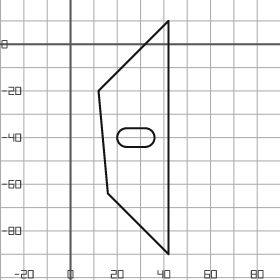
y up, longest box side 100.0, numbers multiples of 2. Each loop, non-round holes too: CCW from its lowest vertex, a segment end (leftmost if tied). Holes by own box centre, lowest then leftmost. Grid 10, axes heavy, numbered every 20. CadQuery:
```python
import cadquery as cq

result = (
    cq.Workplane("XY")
    .moveTo(42.0, -90.0)
    .lineTo(42.0, 10.0)
    .lineTo(12.0, -20.0)
    .lineTo(16.0, -64.0)
    .close()
    .moveTo(24.0, -44.0)
    .lineTo(32.0, -44.0)
    .threePointArc((36.0, -40.0), (32.0, -36.0))
    .lineTo(24.0, -36.0)
    .threePointArc((20.0, -40.0), (24.0, -44.0))
    .close()
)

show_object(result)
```